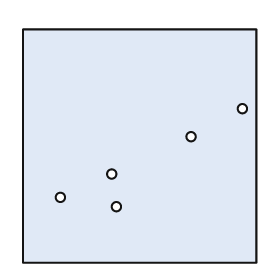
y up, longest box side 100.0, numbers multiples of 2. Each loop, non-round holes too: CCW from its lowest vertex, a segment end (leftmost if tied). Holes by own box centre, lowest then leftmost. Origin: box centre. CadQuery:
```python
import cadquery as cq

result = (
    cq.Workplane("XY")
    .moveTo(-50.0, -50.0)
    .lineTo(50.0, -50.0)
    .lineTo(50.0, 50.0)
    .lineTo(-50.0, 50.0)
    .close()
    .moveTo(-10.0, -26.0)
    .circle(2.0)
    .moveTo(-34.0, -22.0)
    .circle(2.0)
    .moveTo(-12.0, -12.0)
    .circle(2.0)
    .moveTo(22.0, 4.0)
    .circle(2.0)
    .moveTo(44.0, 16.0)
    .circle(2.0)
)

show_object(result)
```